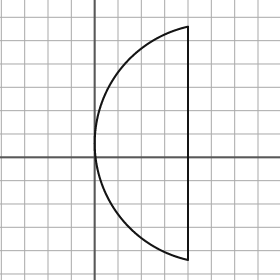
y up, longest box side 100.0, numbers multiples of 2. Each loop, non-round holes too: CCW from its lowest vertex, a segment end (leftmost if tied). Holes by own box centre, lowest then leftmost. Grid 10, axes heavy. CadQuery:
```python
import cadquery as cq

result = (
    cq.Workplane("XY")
    .moveTo(40.0, -44.0)
    .lineTo(40.0, 56.0)
    .threePointArc((0.0, 6.0), (40.0, -44.0))
    .close()
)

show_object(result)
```